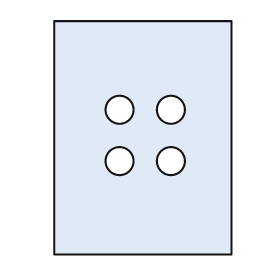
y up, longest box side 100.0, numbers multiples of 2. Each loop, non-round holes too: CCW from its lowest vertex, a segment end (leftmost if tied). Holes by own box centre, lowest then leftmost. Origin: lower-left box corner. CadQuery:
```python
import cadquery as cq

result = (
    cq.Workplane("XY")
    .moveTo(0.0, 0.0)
    .lineTo(76.0, 0.0)
    .lineTo(76.0, 100.0)
    .lineTo(0.0, 100.0)
    .close()
    .moveTo(28.0, 40.0)
    .circle(6.0)
    .moveTo(50.0, 40.0)
    .circle(6.0)
    .moveTo(28.0, 62.0)
    .circle(6.0)
    .moveTo(50.0, 62.0)
    .circle(6.0)
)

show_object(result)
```